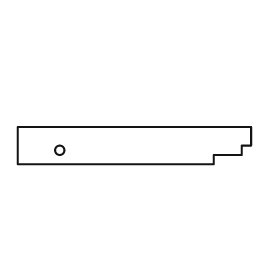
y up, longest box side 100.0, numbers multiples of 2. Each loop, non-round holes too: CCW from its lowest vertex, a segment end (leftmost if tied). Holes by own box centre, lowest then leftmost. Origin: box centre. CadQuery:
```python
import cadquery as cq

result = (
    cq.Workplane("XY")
    .moveTo(-50.0, -8.0)
    .lineTo(34.0, -8.0)
    .lineTo(34.0, -4.0)
    .lineTo(46.0, -4.0)
    .lineTo(46.0, 0.0)
    .lineTo(50.0, 0.0)
    .lineTo(50.0, 8.0)
    .lineTo(-50.0, 8.0)
    .close()
    .moveTo(-32.0, -2.0)
    .circle(2.0)
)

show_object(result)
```